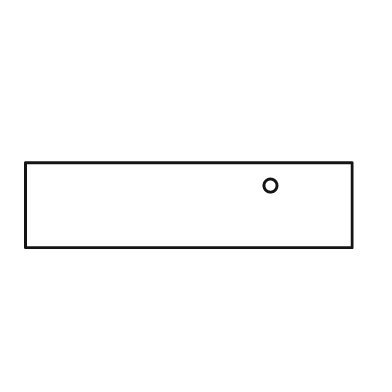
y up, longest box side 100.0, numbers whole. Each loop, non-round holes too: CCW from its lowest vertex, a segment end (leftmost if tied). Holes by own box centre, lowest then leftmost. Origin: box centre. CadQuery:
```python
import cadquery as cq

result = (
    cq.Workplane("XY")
    .moveTo(-50.0, -13.0)
    .lineTo(50.0, -13.0)
    .lineTo(50.0, 13.0)
    .lineTo(-50.0, 13.0)
    .close()
    .moveTo(25.0, 6.0)
    .circle(2.0)
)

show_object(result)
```